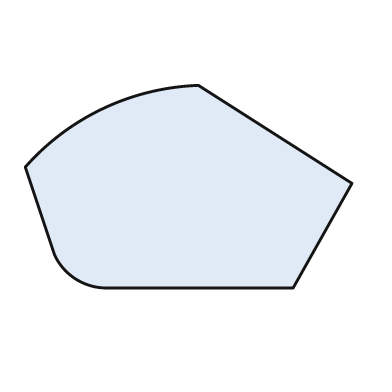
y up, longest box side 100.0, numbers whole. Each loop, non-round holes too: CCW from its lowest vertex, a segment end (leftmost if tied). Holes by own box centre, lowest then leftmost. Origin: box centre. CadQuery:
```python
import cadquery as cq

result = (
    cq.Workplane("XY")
    .moveTo(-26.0, -31.0)
    .lineTo(32.0, -31.0)
    .lineTo(50.0, 1.0)
    .lineTo(3.0, 31.0)
    .threePointArc((-26.0, 24.0), (-50.0, 6.0))
    .lineTo(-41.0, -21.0)
    .threePointArc((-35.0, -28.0), (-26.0, -31.0))
    .close()
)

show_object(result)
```